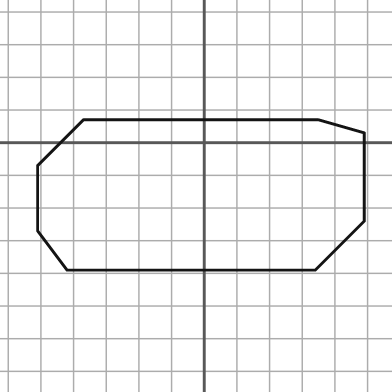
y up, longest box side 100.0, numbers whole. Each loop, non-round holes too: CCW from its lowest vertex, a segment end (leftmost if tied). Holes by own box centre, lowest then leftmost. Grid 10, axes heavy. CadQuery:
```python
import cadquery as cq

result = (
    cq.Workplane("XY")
    .moveTo(-42.0, -39.0)
    .lineTo(34.0, -39.0)
    .lineTo(49.0, -24.0)
    .lineTo(49.0, 3.0)
    .lineTo(35.0, 7.0)
    .lineTo(-37.0, 7.0)
    .lineTo(-51.0, -7.0)
    .lineTo(-51.0, -27.0)
    .close()
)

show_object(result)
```